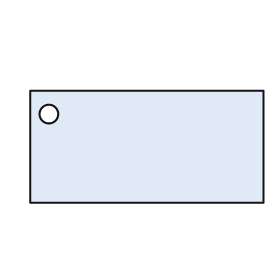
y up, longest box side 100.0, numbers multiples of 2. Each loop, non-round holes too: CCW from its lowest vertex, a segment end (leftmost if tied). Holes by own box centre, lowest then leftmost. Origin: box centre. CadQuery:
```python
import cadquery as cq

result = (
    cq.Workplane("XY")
    .moveTo(-50.0, -24.0)
    .lineTo(50.0, -24.0)
    .lineTo(50.0, 24.0)
    .lineTo(-50.0, 24.0)
    .close()
    .moveTo(-42.0, 14.0)
    .circle(4.0)
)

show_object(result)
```